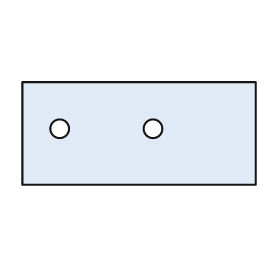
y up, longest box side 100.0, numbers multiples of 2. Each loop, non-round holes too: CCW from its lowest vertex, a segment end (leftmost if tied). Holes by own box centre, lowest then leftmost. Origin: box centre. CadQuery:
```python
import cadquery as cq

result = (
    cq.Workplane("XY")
    .moveTo(-50.0, -22.0)
    .lineTo(50.0, -22.0)
    .lineTo(50.0, 22.0)
    .lineTo(-50.0, 22.0)
    .close()
    .moveTo(-34.0, 2.0)
    .circle(4.0)
    .moveTo(6.0, 2.0)
    .circle(4.0)
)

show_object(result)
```